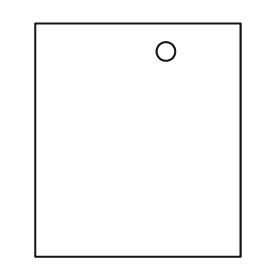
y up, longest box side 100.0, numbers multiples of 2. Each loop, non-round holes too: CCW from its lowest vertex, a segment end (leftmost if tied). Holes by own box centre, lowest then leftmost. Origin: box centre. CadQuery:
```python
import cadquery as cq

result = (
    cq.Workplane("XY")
    .moveTo(-44.0, -50.0)
    .lineTo(44.0, -50.0)
    .lineTo(44.0, 50.0)
    .lineTo(-44.0, 50.0)
    .close()
    .moveTo(12.0, 38.0)
    .circle(4.0)
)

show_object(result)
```